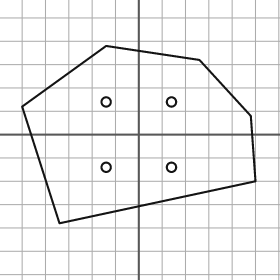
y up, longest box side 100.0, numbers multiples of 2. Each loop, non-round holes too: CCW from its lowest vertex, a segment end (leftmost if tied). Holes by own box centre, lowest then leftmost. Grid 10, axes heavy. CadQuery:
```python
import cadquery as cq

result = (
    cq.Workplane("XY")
    .moveTo(-34.0, -38.0)
    .lineTo(50.0, -20.0)
    .lineTo(48.0, 8.0)
    .lineTo(26.0, 32.0)
    .lineTo(-14.0, 38.0)
    .lineTo(-50.0, 12.0)
    .close()
    .moveTo(-14.0, -14.0)
    .circle(2.0)
    .moveTo(14.0, -14.0)
    .circle(2.0)
    .moveTo(-14.0, 14.0)
    .circle(2.0)
    .moveTo(14.0, 14.0)
    .circle(2.0)
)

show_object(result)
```